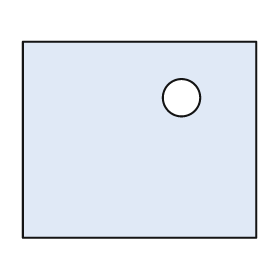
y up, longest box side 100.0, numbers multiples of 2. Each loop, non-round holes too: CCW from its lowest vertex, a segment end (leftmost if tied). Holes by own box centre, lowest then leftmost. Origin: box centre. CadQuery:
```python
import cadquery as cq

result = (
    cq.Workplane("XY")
    .moveTo(-50.0, -42.0)
    .lineTo(50.0, -42.0)
    .lineTo(50.0, 42.0)
    .lineTo(-50.0, 42.0)
    .close()
    .moveTo(18.0, 18.0)
    .circle(8.0)
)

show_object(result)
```